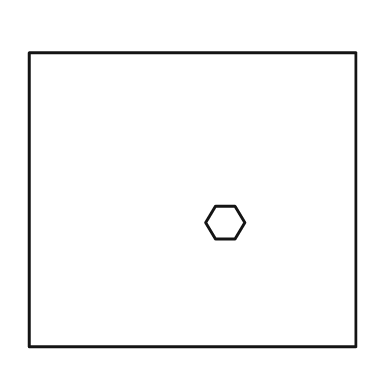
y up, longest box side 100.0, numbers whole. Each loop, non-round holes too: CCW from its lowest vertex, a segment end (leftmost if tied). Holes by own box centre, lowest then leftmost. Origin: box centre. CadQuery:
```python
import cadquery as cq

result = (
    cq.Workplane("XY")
    .moveTo(-50.0, -45.0)
    .lineTo(50.0, -45.0)
    .lineTo(50.0, 45.0)
    .lineTo(-50.0, 45.0)
    .close()
    .moveTo(7.0, -12.0)
    .lineTo(13.0, -12.0)
    .lineTo(16.0, -7.0)
    .lineTo(13.0, -2.0)
    .lineTo(7.0, -2.0)
    .lineTo(4.0, -7.0)
    .close()
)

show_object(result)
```